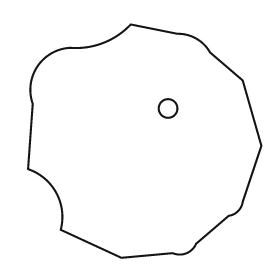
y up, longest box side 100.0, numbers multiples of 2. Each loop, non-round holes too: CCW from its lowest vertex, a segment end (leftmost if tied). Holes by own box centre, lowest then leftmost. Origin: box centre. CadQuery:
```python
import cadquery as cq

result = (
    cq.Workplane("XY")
    .moveTo(-10.0, -50.0)
    .lineTo(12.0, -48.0)
    .threePointArc((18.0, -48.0), (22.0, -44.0))
    .lineTo(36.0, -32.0)
    .threePointArc((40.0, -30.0), (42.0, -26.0))
    .lineTo(50.0, -2.0)
    .lineTo(42.0, 26.0)
    .lineTo(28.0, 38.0)
    .threePointArc((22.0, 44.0), (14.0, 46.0))
    .lineTo(-6.0, 50.0)
    .threePointArc((-18.0, 42.0), (-32.0, 40.0))
    .threePointArc((-46.0, 32.0), (-48.0, 16.0))
    .lineTo(-50.0, -12.0)
    .threePointArc((-38.0, -22.0), (-36.0, -38.0))
    .close()
    .moveTo(10.0, 14.0)
    .circle(4.0)
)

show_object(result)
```